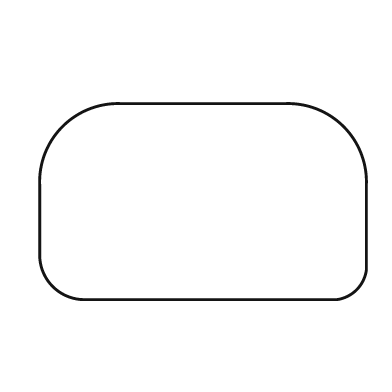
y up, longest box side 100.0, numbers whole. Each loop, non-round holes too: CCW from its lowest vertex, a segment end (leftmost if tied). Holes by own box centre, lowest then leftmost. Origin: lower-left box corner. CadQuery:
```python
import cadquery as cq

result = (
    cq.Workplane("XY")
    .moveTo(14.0, 0.0)
    .lineTo(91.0, 0.0)
    .threePointArc((97.0, 3.0), (100.0, 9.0))
    .lineTo(100.0, 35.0)
    .threePointArc((93.0, 53.0), (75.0, 60.0))
    .lineTo(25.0, 60.0)
    .threePointArc((7.0, 53.0), (0.0, 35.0))
    .lineTo(0.0, 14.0)
    .threePointArc((4.0, 4.0), (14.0, 0.0))
    .close()
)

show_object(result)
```